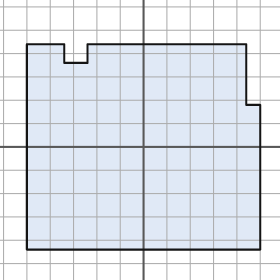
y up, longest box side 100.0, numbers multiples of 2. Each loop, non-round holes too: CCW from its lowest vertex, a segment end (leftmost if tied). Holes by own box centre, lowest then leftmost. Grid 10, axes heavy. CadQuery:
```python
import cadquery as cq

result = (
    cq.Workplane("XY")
    .moveTo(-50.0, -44.0)
    .lineTo(50.0, -44.0)
    .lineTo(50.0, 18.0)
    .lineTo(44.0, 18.0)
    .lineTo(44.0, 44.0)
    .lineTo(-24.0, 44.0)
    .lineTo(-24.0, 36.0)
    .lineTo(-34.0, 36.0)
    .lineTo(-34.0, 44.0)
    .lineTo(-50.0, 44.0)
    .close()
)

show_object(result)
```